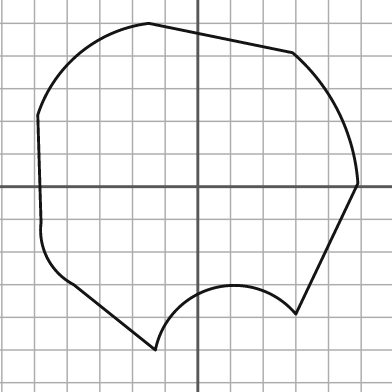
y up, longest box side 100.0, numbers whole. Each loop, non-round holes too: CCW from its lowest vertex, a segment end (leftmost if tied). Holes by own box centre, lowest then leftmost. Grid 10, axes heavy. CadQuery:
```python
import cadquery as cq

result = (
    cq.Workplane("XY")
    .moveTo(-13.0, -50.0)
    .threePointArc((5.0, -31.0), (30.0, -39.0))
    .lineTo(49.0, 1.0)
    .threePointArc((43.0, 23.0), (29.0, 41.0))
    .lineTo(-15.0, 50.0)
    .threePointArc((-36.0, 41.0), (-49.0, 22.0))
    .lineTo(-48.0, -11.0)
    .threePointArc((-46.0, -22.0), (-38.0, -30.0))
    .close()
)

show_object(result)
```